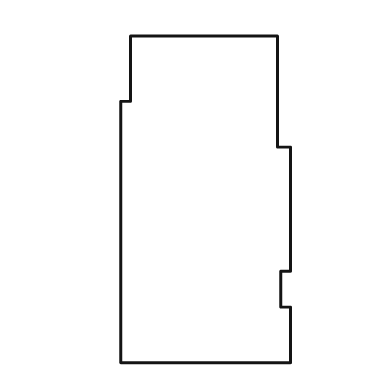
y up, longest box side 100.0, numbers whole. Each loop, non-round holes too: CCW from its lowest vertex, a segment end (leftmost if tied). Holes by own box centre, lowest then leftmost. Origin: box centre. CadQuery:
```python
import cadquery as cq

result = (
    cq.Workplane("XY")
    .moveTo(-26.0, -50.0)
    .lineTo(26.0, -50.0)
    .lineTo(26.0, -33.0)
    .lineTo(23.0, -33.0)
    .lineTo(23.0, -22.0)
    .lineTo(26.0, -22.0)
    .lineTo(26.0, 16.0)
    .lineTo(22.0, 16.0)
    .lineTo(22.0, 50.0)
    .lineTo(-23.0, 50.0)
    .lineTo(-23.0, 30.0)
    .lineTo(-26.0, 30.0)
    .close()
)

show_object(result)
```